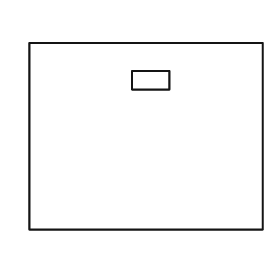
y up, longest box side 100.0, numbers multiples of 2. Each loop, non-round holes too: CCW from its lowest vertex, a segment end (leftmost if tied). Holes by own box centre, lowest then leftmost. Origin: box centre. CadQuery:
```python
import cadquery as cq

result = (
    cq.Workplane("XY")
    .moveTo(-50.0, -40.0)
    .lineTo(50.0, -40.0)
    .lineTo(50.0, 40.0)
    .lineTo(-50.0, 40.0)
    .close()
    .moveTo(-6.0, 20.0)
    .lineTo(10.0, 20.0)
    .lineTo(10.0, 28.0)
    .lineTo(-6.0, 28.0)
    .close()
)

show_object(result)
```